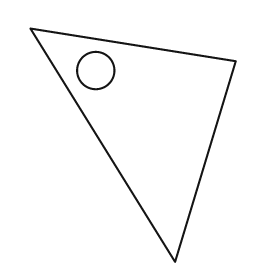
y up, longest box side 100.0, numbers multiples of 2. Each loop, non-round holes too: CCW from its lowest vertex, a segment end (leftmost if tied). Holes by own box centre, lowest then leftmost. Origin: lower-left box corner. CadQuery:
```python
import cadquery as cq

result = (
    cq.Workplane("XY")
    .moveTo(62.0, 0.0)
    .lineTo(88.0, 86.0)
    .lineTo(0.0, 100.0)
    .close()
    .moveTo(28.0, 82.0)
    .circle(8.0)
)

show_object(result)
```